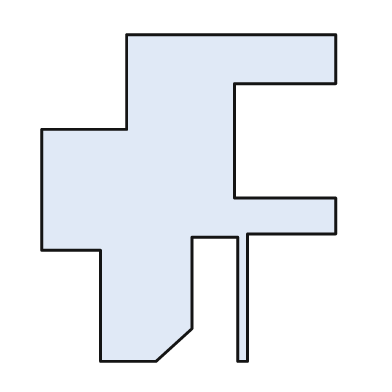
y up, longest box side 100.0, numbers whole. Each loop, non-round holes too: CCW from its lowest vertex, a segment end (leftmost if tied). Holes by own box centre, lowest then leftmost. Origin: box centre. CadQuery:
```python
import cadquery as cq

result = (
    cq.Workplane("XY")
    .moveTo(-27.0, -50.0)
    .lineTo(-10.0, -50.0)
    .lineTo(1.0, -40.0)
    .lineTo(1.0, -12.0)
    .lineTo(15.0, -12.0)
    .lineTo(15.0, -50.0)
    .lineTo(18.0, -50.0)
    .lineTo(18.0, -11.0)
    .lineTo(45.0, -11.0)
    .lineTo(45.0, 0.0)
    .lineTo(14.0, 0.0)
    .lineTo(14.0, 35.0)
    .lineTo(45.0, 35.0)
    .lineTo(45.0, 50.0)
    .lineTo(-19.0, 50.0)
    .lineTo(-19.0, 21.0)
    .lineTo(-45.0, 21.0)
    .lineTo(-45.0, -16.0)
    .lineTo(-27.0, -16.0)
    .close()
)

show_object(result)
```